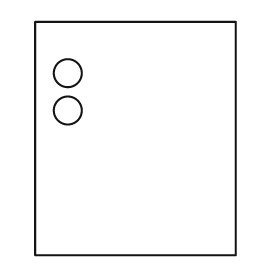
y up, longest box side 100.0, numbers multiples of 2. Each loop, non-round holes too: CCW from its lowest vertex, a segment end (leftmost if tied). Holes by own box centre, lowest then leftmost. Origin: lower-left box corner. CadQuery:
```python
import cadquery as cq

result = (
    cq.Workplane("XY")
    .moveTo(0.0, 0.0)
    .lineTo(86.0, 0.0)
    .lineTo(86.0, 100.0)
    .lineTo(0.0, 100.0)
    .close()
    .moveTo(14.0, 62.0)
    .circle(6.0)
    .moveTo(14.0, 78.0)
    .circle(6.0)
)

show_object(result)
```